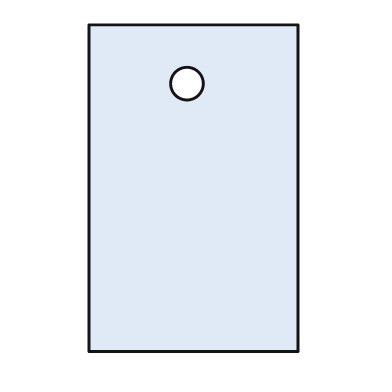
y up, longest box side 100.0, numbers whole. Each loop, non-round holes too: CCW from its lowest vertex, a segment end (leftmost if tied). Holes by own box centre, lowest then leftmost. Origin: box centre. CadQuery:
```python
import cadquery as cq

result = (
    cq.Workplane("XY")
    .moveTo(-32.0, -50.0)
    .lineTo(32.0, -50.0)
    .lineTo(32.0, 50.0)
    .lineTo(-32.0, 50.0)
    .close()
    .moveTo(-2.0, 32.0)
    .circle(5.0)
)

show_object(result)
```